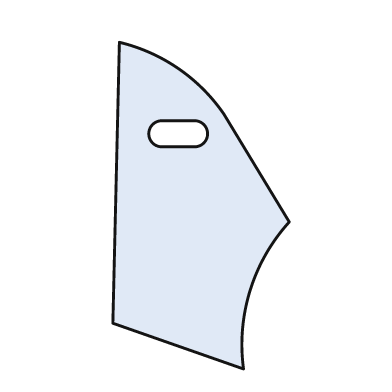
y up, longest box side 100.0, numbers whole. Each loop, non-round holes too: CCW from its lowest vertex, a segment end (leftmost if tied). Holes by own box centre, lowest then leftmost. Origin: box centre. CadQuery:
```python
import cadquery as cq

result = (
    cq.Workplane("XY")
    .moveTo(13.0, -50.0)
    .threePointArc((15.0, -26.0), (27.0, -5.0))
    .lineTo(7.0, 28.0)
    .threePointArc((-7.0, 42.0), (-25.0, 50.0))
    .lineTo(-27.0, -36.0)
    .close()
    .moveTo(-12.0, 18.0)
    .lineTo(-2.0, 18.0)
    .threePointArc((2.0, 22.0), (-2.0, 26.0))
    .lineTo(-12.0, 26.0)
    .threePointArc((-16.0, 22.0), (-12.0, 18.0))
    .close()
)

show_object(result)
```